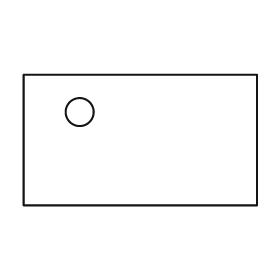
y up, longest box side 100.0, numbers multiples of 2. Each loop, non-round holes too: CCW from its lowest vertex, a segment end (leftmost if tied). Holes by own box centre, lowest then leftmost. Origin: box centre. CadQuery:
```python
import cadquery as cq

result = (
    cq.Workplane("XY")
    .moveTo(-50.0, -28.0)
    .lineTo(50.0, -28.0)
    .lineTo(50.0, 28.0)
    .lineTo(-50.0, 28.0)
    .close()
    .moveTo(-26.0, 12.0)
    .circle(6.0)
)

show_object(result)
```